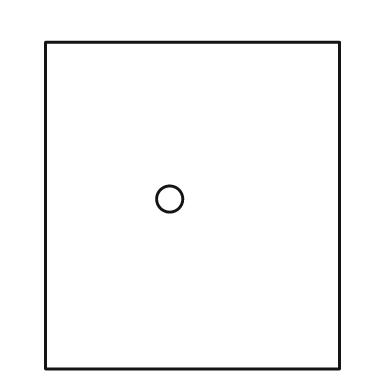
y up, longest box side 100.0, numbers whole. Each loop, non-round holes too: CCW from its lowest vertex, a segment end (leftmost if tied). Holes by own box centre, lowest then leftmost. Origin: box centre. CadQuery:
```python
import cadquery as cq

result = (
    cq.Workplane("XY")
    .moveTo(-45.0, -50.0)
    .lineTo(45.0, -50.0)
    .lineTo(45.0, 50.0)
    .lineTo(-45.0, 50.0)
    .close()
    .moveTo(-7.0, 2.0)
    .circle(4.0)
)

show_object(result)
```